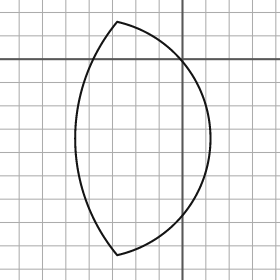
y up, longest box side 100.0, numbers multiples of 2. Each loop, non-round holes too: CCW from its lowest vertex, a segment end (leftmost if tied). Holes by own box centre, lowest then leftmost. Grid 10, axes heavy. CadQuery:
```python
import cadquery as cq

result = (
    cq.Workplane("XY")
    .moveTo(-28.0, -84.0)
    .threePointArc((12.0, -34.0), (-28.0, 16.0))
    .threePointArc((-46.0, -34.0), (-28.0, -84.0))
    .close()
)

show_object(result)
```